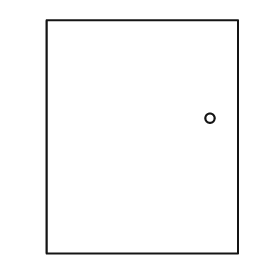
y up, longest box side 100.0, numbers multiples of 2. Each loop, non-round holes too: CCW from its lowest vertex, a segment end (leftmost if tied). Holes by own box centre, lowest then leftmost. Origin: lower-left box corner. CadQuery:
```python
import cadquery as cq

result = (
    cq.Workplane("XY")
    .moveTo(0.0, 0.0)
    .lineTo(82.0, 0.0)
    .lineTo(82.0, 100.0)
    .lineTo(0.0, 100.0)
    .close()
    .moveTo(70.0, 58.0)
    .circle(2.0)
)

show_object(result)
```